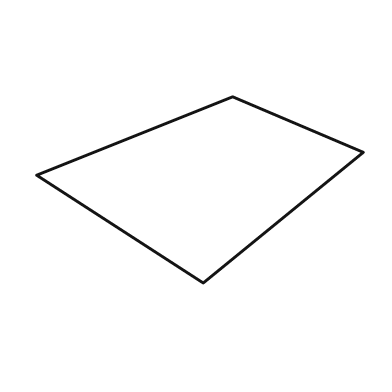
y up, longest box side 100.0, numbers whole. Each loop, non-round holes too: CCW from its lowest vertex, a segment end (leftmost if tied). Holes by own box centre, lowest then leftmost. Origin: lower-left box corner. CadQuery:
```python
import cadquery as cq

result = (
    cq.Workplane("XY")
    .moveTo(51.0, 0.0)
    .lineTo(100.0, 40.0)
    .lineTo(60.0, 57.0)
    .lineTo(0.0, 33.0)
    .close()
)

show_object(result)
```